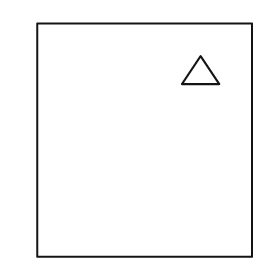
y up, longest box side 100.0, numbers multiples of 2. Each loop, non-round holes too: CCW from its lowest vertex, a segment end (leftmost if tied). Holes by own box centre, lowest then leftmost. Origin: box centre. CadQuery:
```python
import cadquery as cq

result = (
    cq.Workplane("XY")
    .moveTo(-46.0, -50.0)
    .lineTo(46.0, -50.0)
    .lineTo(46.0, 50.0)
    .lineTo(-46.0, 50.0)
    .close()
    .moveTo(16.0, 24.0)
    .lineTo(32.0, 24.0)
    .lineTo(24.0, 36.0)
    .close()
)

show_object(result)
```